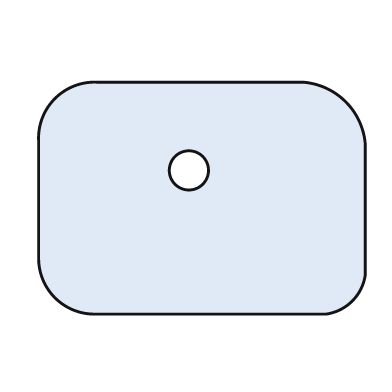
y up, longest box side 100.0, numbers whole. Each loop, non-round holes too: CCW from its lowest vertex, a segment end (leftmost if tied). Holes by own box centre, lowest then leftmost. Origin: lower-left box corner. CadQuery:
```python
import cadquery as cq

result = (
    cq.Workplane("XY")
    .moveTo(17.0, 0.0)
    .lineTo(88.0, 0.0)
    .threePointArc((96.0, 4.0), (100.0, 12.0))
    .lineTo(100.0, 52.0)
    .threePointArc((94.0, 65.0), (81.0, 71.0))
    .lineTo(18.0, 71.0)
    .threePointArc((5.0, 66.0), (0.0, 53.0))
    .lineTo(0.0, 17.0)
    .threePointArc((5.0, 5.0), (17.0, 0.0))
    .close()
    .moveTo(46.0, 44.0)
    .circle(6.0)
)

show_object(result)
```